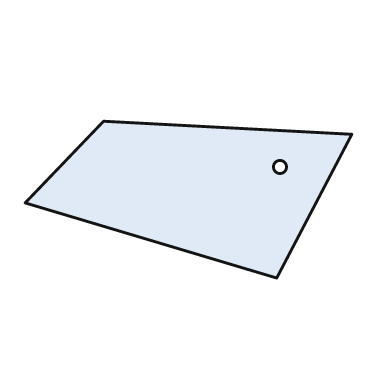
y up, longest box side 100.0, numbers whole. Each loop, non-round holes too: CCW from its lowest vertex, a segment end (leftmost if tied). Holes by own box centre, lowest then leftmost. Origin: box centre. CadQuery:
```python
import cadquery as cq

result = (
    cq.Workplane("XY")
    .moveTo(27.0, -24.0)
    .lineTo(50.0, 20.0)
    .lineTo(-26.0, 24.0)
    .lineTo(-50.0, -1.0)
    .close()
    .moveTo(28.0, 10.0)
    .circle(2.0)
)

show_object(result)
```